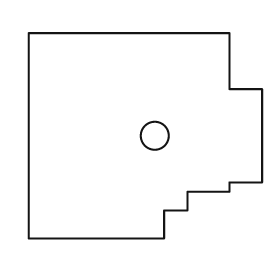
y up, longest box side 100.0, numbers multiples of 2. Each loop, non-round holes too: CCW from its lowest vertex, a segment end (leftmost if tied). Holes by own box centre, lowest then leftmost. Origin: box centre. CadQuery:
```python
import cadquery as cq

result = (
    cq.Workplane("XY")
    .moveTo(-50.0, -44.0)
    .lineTo(8.0, -44.0)
    .lineTo(8.0, -32.0)
    .lineTo(18.0, -32.0)
    .lineTo(18.0, -24.0)
    .lineTo(36.0, -24.0)
    .lineTo(36.0, -20.0)
    .lineTo(50.0, -20.0)
    .lineTo(50.0, 20.0)
    .lineTo(36.0, 20.0)
    .lineTo(36.0, 44.0)
    .lineTo(-50.0, 44.0)
    .close()
    .moveTo(4.0, 0.0)
    .circle(6.0)
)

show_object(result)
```